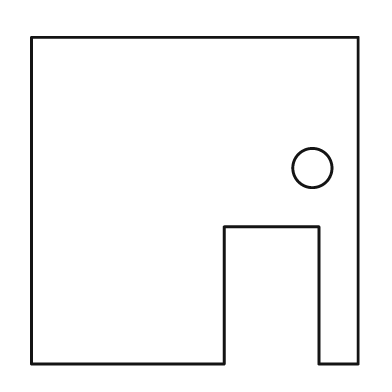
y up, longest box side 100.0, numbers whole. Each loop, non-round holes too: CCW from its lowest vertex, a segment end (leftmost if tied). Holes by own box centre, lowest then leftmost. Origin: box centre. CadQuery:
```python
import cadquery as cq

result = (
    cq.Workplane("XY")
    .moveTo(-50.0, -50.0)
    .lineTo(9.0, -50.0)
    .lineTo(9.0, -8.0)
    .lineTo(38.0, -8.0)
    .lineTo(38.0, -50.0)
    .lineTo(50.0, -50.0)
    .lineTo(50.0, 50.0)
    .lineTo(-50.0, 50.0)
    .close()
    .moveTo(36.0, 10.0)
    .circle(6.0)
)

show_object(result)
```